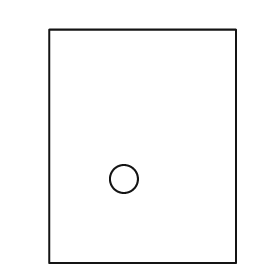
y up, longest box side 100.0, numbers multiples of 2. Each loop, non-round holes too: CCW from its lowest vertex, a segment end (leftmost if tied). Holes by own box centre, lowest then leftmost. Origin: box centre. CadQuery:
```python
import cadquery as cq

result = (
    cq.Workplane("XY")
    .moveTo(-40.0, -50.0)
    .lineTo(40.0, -50.0)
    .lineTo(40.0, 50.0)
    .lineTo(-40.0, 50.0)
    .close()
    .moveTo(-8.0, -14.0)
    .circle(6.0)
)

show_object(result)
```